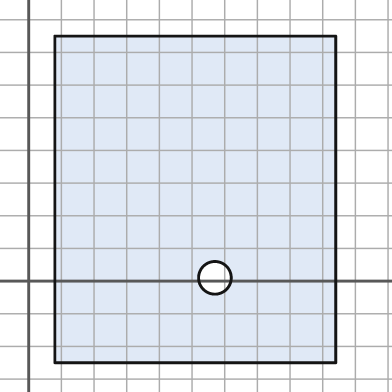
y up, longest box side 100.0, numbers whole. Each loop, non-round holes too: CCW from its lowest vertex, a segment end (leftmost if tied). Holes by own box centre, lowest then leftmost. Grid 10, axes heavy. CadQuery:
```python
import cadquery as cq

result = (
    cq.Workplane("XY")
    .moveTo(8.0, -25.0)
    .lineTo(94.0, -25.0)
    .lineTo(94.0, 75.0)
    .lineTo(8.0, 75.0)
    .close()
    .moveTo(57.0, 1.0)
    .circle(5.0)
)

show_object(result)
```